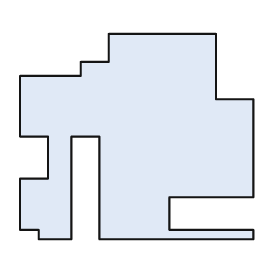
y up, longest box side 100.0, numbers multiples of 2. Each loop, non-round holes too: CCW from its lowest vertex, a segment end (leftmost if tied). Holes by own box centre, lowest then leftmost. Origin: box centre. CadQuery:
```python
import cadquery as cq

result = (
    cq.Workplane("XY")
    .moveTo(-42.0, -44.0)
    .lineTo(-28.0, -44.0)
    .lineTo(-28.0, 0.0)
    .lineTo(-16.0, 0.0)
    .lineTo(-16.0, -44.0)
    .lineTo(50.0, -44.0)
    .lineTo(50.0, -40.0)
    .lineTo(14.0, -40.0)
    .lineTo(14.0, -26.0)
    .lineTo(50.0, -26.0)
    .lineTo(50.0, 16.0)
    .lineTo(34.0, 16.0)
    .lineTo(34.0, 44.0)
    .lineTo(-12.0, 44.0)
    .lineTo(-12.0, 32.0)
    .lineTo(-24.0, 32.0)
    .lineTo(-24.0, 26.0)
    .lineTo(-50.0, 26.0)
    .lineTo(-50.0, 0.0)
    .lineTo(-38.0, 0.0)
    .lineTo(-38.0, -18.0)
    .lineTo(-50.0, -18.0)
    .lineTo(-50.0, -40.0)
    .lineTo(-42.0, -40.0)
    .close()
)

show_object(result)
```